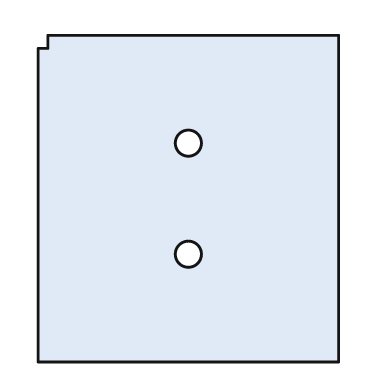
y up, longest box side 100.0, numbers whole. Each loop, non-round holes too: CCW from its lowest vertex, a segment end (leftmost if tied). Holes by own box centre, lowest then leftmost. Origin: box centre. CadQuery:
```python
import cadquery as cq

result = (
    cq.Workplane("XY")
    .moveTo(-46.0, -50.0)
    .lineTo(46.0, -50.0)
    .lineTo(46.0, 50.0)
    .lineTo(-43.0, 50.0)
    .lineTo(-43.0, 46.0)
    .lineTo(-46.0, 46.0)
    .close()
    .moveTo(0.0, -17.0)
    .circle(4.0)
    .moveTo(0.0, 17.0)
    .circle(4.0)
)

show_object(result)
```